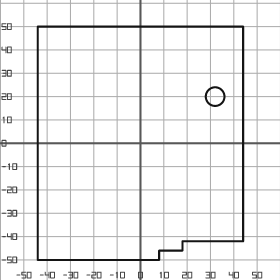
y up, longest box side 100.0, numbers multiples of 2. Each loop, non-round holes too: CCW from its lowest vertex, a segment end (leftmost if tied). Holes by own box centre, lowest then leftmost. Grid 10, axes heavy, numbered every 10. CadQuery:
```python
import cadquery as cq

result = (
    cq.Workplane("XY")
    .moveTo(-44.0, -50.0)
    .lineTo(8.0, -50.0)
    .lineTo(8.0, -46.0)
    .lineTo(18.0, -46.0)
    .lineTo(18.0, -42.0)
    .lineTo(44.0, -42.0)
    .lineTo(44.0, 50.0)
    .lineTo(-44.0, 50.0)
    .close()
    .moveTo(32.0, 20.0)
    .circle(4.0)
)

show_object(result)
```